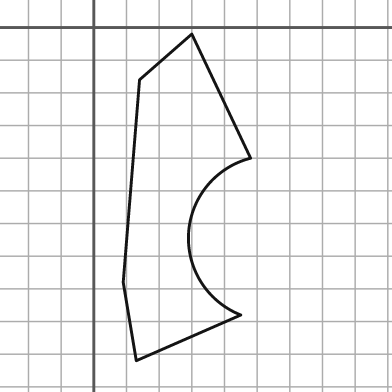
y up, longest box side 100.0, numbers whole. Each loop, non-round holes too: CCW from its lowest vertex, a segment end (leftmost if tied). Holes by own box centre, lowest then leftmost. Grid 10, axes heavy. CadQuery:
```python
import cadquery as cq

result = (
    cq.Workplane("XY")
    .moveTo(13.0, -102.0)
    .lineTo(45.0, -88.0)
    .threePointArc((29.0, -63.0), (48.0, -40.0))
    .lineTo(30.0, -2.0)
    .lineTo(14.0, -16.0)
    .lineTo(9.0, -78.0)
    .close()
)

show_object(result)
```